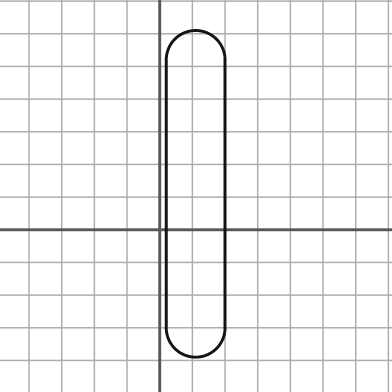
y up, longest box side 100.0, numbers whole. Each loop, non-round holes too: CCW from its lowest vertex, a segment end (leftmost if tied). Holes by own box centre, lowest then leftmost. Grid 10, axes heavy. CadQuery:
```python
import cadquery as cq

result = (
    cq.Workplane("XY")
    .moveTo(2.0, -30.0)
    .threePointArc((11.0, -39.0), (20.0, -30.0))
    .lineTo(20.0, 52.0)
    .threePointArc((11.0, 61.0), (2.0, 52.0))
    .close()
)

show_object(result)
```